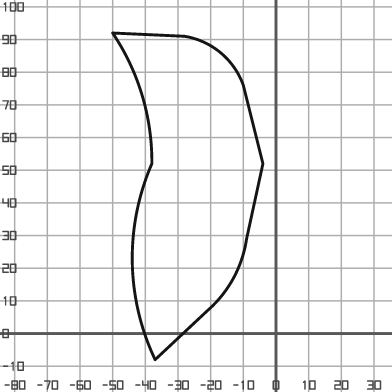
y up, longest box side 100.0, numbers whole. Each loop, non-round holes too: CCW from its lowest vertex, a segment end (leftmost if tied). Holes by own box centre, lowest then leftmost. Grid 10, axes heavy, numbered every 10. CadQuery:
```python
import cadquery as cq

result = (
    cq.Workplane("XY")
    .moveTo(-37.0, -8.0)
    .lineTo(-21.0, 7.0)
    .threePointArc((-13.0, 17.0), (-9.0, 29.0))
    .lineTo(-4.0, 52.0)
    .lineTo(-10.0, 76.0)
    .threePointArc((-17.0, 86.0), (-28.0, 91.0))
    .lineTo(-50.0, 92.0)
    .threePointArc((-41.0, 73.0), (-38.0, 52.0))
    .threePointArc((-44.0, 22.0), (-37.0, -8.0))
    .close()
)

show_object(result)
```